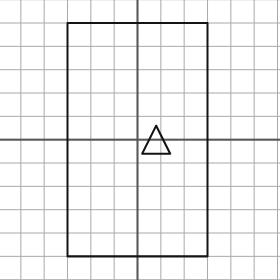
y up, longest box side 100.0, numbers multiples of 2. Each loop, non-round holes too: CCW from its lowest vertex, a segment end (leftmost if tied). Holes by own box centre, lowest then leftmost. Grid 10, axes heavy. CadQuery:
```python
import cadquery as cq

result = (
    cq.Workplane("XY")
    .moveTo(-30.0, -50.0)
    .lineTo(30.0, -50.0)
    .lineTo(30.0, 50.0)
    .lineTo(-30.0, 50.0)
    .close()
    .moveTo(2.0, -6.0)
    .lineTo(14.0, -6.0)
    .lineTo(8.0, 6.0)
    .close()
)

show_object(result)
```